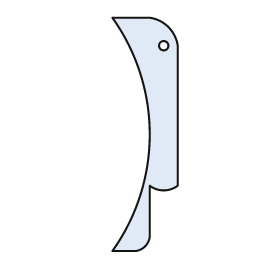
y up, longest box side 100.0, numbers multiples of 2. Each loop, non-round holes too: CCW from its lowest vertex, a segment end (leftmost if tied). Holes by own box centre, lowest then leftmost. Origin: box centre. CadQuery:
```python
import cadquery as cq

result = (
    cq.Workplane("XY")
    .moveTo(-14.0, -50.0)
    .lineTo(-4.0, -50.0)
    .threePointArc((0.0, -48.0), (2.0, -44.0))
    .lineTo(2.0, -22.0)
    .threePointArc((8.0, -24.0), (14.0, -22.0))
    .lineTo(14.0, 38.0)
    .threePointArc((10.0, 46.0), (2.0, 50.0))
    .lineTo(-14.0, 50.0)
    .threePointArc((2.0, 0.0), (-14.0, -50.0))
    .close()
    .moveTo(8.0, 38.0)
    .circle(2.0)
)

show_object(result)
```